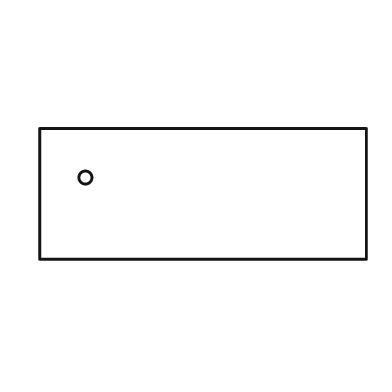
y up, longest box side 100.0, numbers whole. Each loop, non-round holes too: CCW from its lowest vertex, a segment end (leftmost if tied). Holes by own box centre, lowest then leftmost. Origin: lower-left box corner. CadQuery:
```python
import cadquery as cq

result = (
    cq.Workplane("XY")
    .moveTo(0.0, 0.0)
    .lineTo(100.0, 0.0)
    .lineTo(100.0, 40.0)
    .lineTo(0.0, 40.0)
    .close()
    .moveTo(14.0, 25.0)
    .circle(2.0)
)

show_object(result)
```